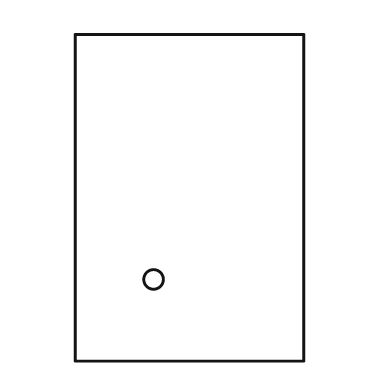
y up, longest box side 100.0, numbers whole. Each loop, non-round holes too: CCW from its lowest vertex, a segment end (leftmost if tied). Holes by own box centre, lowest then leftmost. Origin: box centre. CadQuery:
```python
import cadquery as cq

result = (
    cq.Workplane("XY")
    .moveTo(-35.0, -50.0)
    .lineTo(35.0, -50.0)
    .lineTo(35.0, 50.0)
    .lineTo(-35.0, 50.0)
    .close()
    .moveTo(-11.0, -25.0)
    .circle(3.0)
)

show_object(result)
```